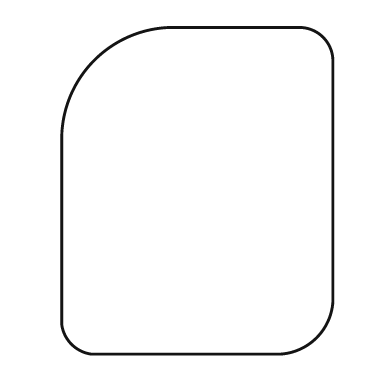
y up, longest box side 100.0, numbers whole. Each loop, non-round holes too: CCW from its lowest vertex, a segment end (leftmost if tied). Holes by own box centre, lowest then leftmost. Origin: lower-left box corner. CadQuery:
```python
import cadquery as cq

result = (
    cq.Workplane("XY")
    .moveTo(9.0, 0.0)
    .lineTo(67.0, 0.0)
    .threePointArc((78.0, 5.0), (83.0, 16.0))
    .lineTo(83.0, 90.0)
    .threePointArc((80.0, 97.0), (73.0, 100.0))
    .lineTo(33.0, 100.0)
    .threePointArc((10.0, 90.0), (0.0, 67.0))
    .lineTo(0.0, 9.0)
    .threePointArc((3.0, 3.0), (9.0, 0.0))
    .close()
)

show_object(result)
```